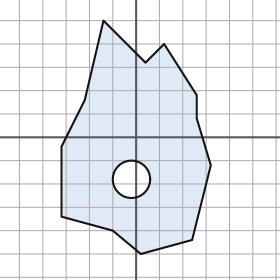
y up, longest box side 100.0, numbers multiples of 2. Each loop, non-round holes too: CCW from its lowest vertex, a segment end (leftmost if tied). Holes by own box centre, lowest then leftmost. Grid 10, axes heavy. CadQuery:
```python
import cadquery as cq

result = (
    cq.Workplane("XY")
    .moveTo(2.0, -50.0)
    .lineTo(24.0, -44.0)
    .lineTo(32.0, -12.0)
    .lineTo(26.0, 8.0)
    .lineTo(26.0, 18.0)
    .lineTo(12.0, 40.0)
    .lineTo(4.0, 32.0)
    .lineTo(-14.0, 50.0)
    .lineTo(-22.0, 16.0)
    .lineTo(-32.0, -4.0)
    .lineTo(-32.0, -34.0)
    .lineTo(-10.0, -40.0)
    .close()
    .moveTo(-2.0, -18.0)
    .circle(8.0)
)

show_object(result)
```